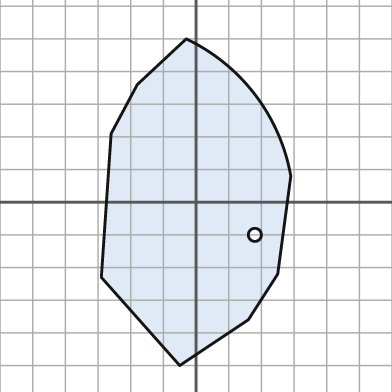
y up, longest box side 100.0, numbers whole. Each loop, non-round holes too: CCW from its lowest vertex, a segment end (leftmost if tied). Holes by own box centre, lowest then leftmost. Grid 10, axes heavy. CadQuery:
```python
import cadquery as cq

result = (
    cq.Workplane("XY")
    .moveTo(-5.0, -50.0)
    .lineTo(16.0, -36.0)
    .lineTo(25.0, -22.0)
    .lineTo(29.0, 8.0)
    .threePointArc((18.0, 33.0), (-3.0, 50.0))
    .lineTo(-18.0, 36.0)
    .lineTo(-26.0, 21.0)
    .lineTo(-29.0, -23.0)
    .close()
    .moveTo(18.0, -10.0)
    .circle(2.0)
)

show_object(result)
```